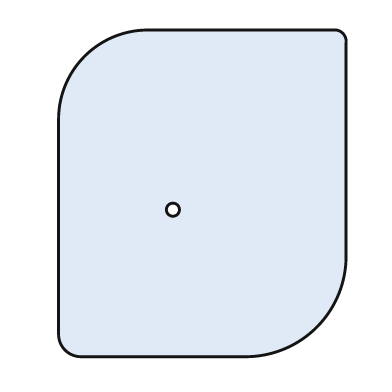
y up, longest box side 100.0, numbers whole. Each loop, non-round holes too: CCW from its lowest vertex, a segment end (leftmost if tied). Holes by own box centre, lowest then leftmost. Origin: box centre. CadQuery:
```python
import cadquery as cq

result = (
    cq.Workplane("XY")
    .moveTo(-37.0, -50.0)
    .lineTo(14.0, -50.0)
    .threePointArc((35.0, -41.0), (44.0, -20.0))
    .lineTo(44.0, 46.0)
    .threePointArc((43.0, 49.0), (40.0, 50.0))
    .lineTo(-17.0, 50.0)
    .threePointArc((-36.0, 42.0), (-44.0, 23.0))
    .lineTo(-44.0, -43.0)
    .threePointArc((-42.0, -48.0), (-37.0, -50.0))
    .close()
    .moveTo(-9.0, -5.0)
    .circle(2.0)
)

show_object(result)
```